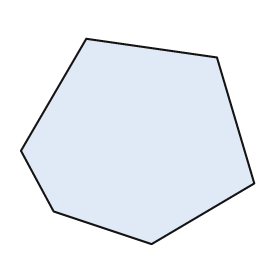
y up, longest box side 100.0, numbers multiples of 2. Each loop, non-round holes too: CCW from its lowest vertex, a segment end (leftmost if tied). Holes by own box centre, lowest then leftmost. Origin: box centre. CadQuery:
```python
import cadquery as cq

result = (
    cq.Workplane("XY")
    .moveTo(6.0, -44.0)
    .lineTo(50.0, -18.0)
    .lineTo(34.0, 36.0)
    .lineTo(-22.0, 44.0)
    .lineTo(-50.0, -4.0)
    .lineTo(-36.0, -30.0)
    .close()
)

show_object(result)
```